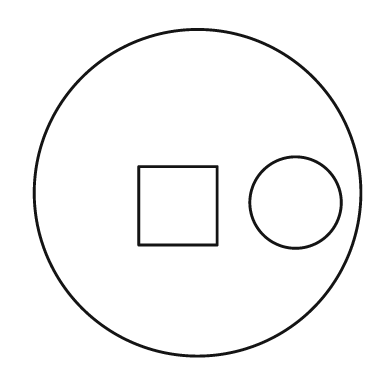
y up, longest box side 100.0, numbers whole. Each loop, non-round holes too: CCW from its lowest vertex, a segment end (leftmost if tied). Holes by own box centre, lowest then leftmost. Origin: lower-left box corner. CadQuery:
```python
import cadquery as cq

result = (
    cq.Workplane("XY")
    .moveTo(50.0, 50.0)
    .circle(50.0)
    .moveTo(32.0, 34.0)
    .lineTo(56.0, 34.0)
    .lineTo(56.0, 58.0)
    .lineTo(32.0, 58.0)
    .close()
    .moveTo(80.0, 47.0)
    .circle(14.0)
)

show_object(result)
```